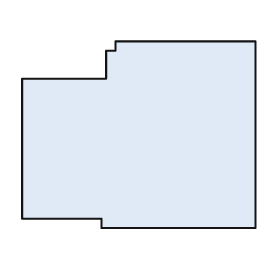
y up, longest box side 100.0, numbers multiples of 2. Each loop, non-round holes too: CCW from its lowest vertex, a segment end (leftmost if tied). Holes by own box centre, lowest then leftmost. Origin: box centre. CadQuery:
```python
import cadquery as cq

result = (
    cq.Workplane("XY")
    .moveTo(-16.0, -40.0)
    .lineTo(50.0, -40.0)
    .lineTo(50.0, 40.0)
    .lineTo(-10.0, 40.0)
    .lineTo(-10.0, 36.0)
    .lineTo(-14.0, 36.0)
    .lineTo(-14.0, 24.0)
    .lineTo(-50.0, 24.0)
    .lineTo(-50.0, -36.0)
    .lineTo(-16.0, -36.0)
    .close()
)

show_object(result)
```